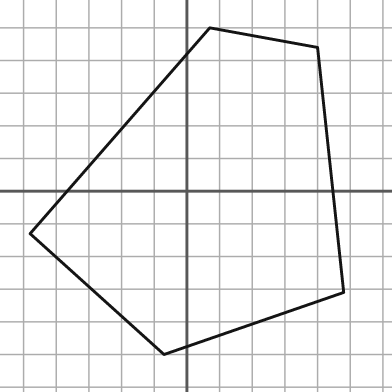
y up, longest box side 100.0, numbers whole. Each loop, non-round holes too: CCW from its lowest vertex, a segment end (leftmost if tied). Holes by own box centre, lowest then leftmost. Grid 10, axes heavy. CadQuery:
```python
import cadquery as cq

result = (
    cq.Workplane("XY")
    .moveTo(-7.0, -50.0)
    .lineTo(48.0, -31.0)
    .lineTo(40.0, 44.0)
    .lineTo(7.0, 50.0)
    .lineTo(-48.0, -13.0)
    .close()
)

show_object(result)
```